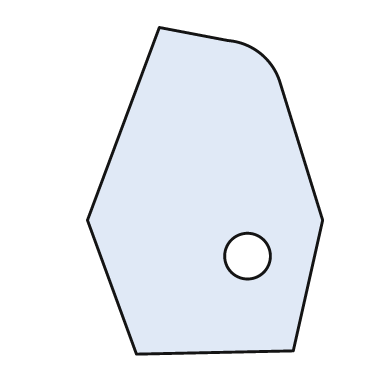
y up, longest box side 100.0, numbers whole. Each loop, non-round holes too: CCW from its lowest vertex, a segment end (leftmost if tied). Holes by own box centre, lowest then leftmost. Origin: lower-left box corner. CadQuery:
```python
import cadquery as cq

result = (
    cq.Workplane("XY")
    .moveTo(15.0, 0.0)
    .lineTo(63.0, 1.0)
    .lineTo(72.0, 41.0)
    .lineTo(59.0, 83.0)
    .threePointArc((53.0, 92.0), (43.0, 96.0))
    .lineTo(22.0, 100.0)
    .lineTo(0.0, 41.0)
    .close()
    .moveTo(49.0, 30.0)
    .circle(7.0)
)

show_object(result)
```